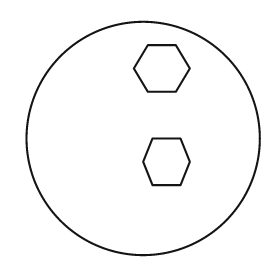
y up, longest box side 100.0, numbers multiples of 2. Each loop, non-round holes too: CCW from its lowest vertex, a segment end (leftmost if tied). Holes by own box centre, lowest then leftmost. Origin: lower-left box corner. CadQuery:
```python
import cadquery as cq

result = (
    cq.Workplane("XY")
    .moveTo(50.0, 50.0)
    .circle(50.0)
    .moveTo(54.0, 30.0)
    .lineTo(66.0, 30.0)
    .lineTo(70.0, 40.0)
    .lineTo(66.0, 50.0)
    .lineTo(54.0, 50.0)
    .lineTo(50.0, 40.0)
    .close()
    .moveTo(52.0, 70.0)
    .lineTo(64.0, 70.0)
    .lineTo(70.0, 80.0)
    .lineTo(64.0, 90.0)
    .lineTo(52.0, 90.0)
    .lineTo(46.0, 80.0)
    .close()
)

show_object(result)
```